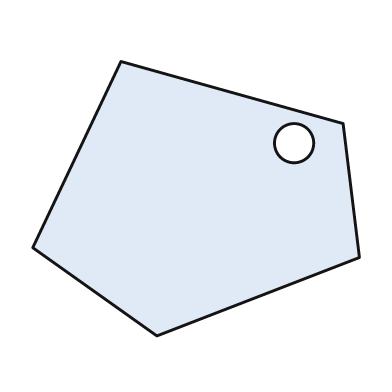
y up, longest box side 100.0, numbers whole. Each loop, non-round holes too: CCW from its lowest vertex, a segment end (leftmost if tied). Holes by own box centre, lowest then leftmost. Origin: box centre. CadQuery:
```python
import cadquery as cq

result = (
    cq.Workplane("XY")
    .moveTo(-12.0, -42.0)
    .lineTo(50.0, -18.0)
    .lineTo(45.0, 23.0)
    .lineTo(-23.0, 42.0)
    .lineTo(-50.0, -15.0)
    .close()
    .moveTo(30.0, 17.0)
    .circle(6.0)
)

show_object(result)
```